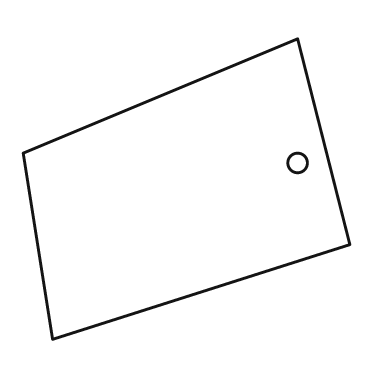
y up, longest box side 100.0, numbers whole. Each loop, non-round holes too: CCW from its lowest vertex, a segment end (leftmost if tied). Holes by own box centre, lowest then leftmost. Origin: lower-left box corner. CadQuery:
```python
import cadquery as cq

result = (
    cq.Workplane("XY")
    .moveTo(9.0, 0.0)
    .lineTo(100.0, 29.0)
    .lineTo(84.0, 92.0)
    .lineTo(0.0, 57.0)
    .close()
    .moveTo(84.0, 54.0)
    .circle(3.0)
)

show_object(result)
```